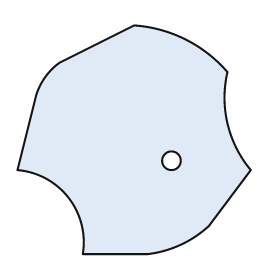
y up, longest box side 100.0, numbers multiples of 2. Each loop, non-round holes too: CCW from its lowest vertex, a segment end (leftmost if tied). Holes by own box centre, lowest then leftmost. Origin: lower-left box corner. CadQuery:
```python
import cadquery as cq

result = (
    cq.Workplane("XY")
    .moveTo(28.0, 0.0)
    .lineTo(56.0, 0.0)
    .threePointArc((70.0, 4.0), (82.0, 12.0))
    .lineTo(100.0, 36.0)
    .threePointArc((90.0, 56.0), (90.0, 78.0))
    .threePointArc((72.0, 92.0), (50.0, 98.0))
    .lineTo(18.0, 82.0)
    .threePointArc((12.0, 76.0), (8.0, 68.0))
    .lineTo(0.0, 36.0)
    .threePointArc((22.0, 24.0), (28.0, 0.0))
    .close()
    .moveTo(66.0, 40.0)
    .circle(4.0)
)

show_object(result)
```